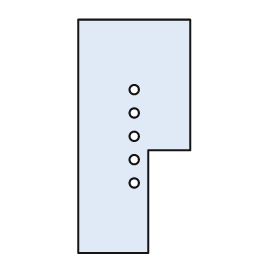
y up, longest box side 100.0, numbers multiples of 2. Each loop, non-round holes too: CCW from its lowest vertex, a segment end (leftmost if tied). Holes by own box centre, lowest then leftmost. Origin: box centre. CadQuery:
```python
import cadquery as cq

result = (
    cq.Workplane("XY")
    .moveTo(-24.0, -50.0)
    .lineTo(6.0, -50.0)
    .lineTo(6.0, -6.0)
    .lineTo(24.0, -6.0)
    .lineTo(24.0, 50.0)
    .lineTo(-24.0, 50.0)
    .close()
    .moveTo(0.0, -20.0)
    .circle(2.0)
    .moveTo(0.0, -10.0)
    .circle(2.0)
    .moveTo(0.0, 0.0)
    .circle(2.0)
    .moveTo(0.0, 10.0)
    .circle(2.0)
    .moveTo(0.0, 20.0)
    .circle(2.0)
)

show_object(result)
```